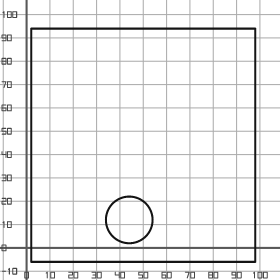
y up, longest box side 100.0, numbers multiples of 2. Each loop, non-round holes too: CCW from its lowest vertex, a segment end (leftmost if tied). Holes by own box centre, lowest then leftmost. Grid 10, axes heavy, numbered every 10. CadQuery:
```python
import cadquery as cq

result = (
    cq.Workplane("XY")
    .moveTo(2.0, -6.0)
    .lineTo(98.0, -6.0)
    .lineTo(98.0, 94.0)
    .lineTo(2.0, 94.0)
    .close()
    .moveTo(44.0, 12.0)
    .circle(10.0)
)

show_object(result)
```